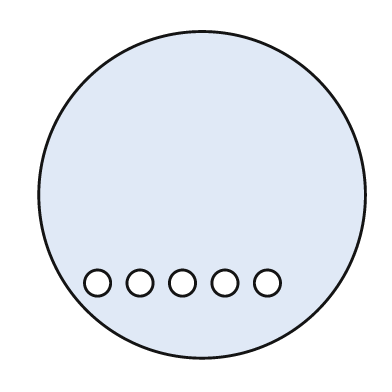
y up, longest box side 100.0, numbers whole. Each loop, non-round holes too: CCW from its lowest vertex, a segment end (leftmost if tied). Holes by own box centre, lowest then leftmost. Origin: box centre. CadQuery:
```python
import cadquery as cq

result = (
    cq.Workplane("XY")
    .moveTo(0.0, 0.0)
    .circle(50.0)
    .moveTo(-32.0, -27.0)
    .circle(4.0)
    .moveTo(-19.0, -27.0)
    .circle(4.0)
    .moveTo(-6.0, -27.0)
    .circle(4.0)
    .moveTo(7.0, -27.0)
    .circle(4.0)
    .moveTo(20.0, -27.0)
    .circle(4.0)
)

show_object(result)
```